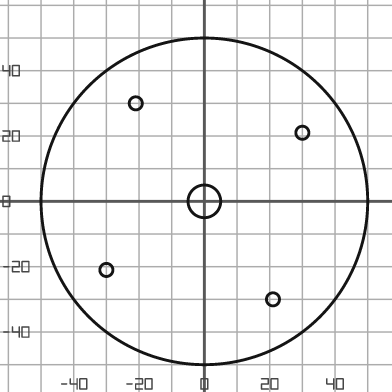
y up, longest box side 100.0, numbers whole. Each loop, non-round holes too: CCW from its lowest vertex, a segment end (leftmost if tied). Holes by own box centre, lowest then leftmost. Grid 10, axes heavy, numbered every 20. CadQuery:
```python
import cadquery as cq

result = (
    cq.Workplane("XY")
    .moveTo(0.0, 0.0)
    .circle(50.0)
    .moveTo(21.0, -30.0)
    .circle(2.0)
    .moveTo(-30.0, -21.0)
    .circle(2.0)
    .moveTo(0.0, 0.0)
    .circle(5.0)
    .moveTo(30.0, 21.0)
    .circle(2.0)
    .moveTo(-21.0, 30.0)
    .circle(2.0)
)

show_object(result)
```